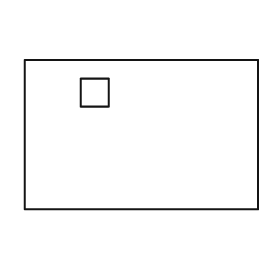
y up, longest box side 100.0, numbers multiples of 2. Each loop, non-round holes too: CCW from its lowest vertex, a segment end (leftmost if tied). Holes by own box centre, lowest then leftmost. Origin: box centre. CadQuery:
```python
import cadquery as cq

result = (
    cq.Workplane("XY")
    .moveTo(-50.0, -32.0)
    .lineTo(50.0, -32.0)
    .lineTo(50.0, 32.0)
    .lineTo(-50.0, 32.0)
    .close()
    .moveTo(-26.0, 12.0)
    .lineTo(-14.0, 12.0)
    .lineTo(-14.0, 24.0)
    .lineTo(-26.0, 24.0)
    .close()
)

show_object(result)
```